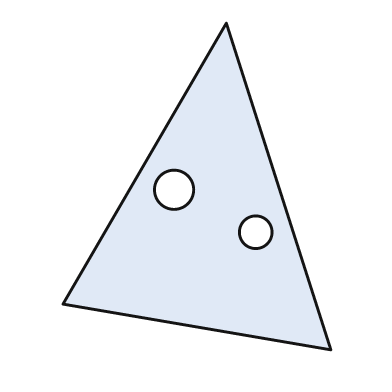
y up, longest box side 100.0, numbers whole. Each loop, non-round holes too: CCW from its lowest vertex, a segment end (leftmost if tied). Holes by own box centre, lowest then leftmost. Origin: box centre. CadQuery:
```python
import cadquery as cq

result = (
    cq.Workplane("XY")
    .moveTo(41.0, -50.0)
    .lineTo(9.0, 50.0)
    .lineTo(-41.0, -36.0)
    .close()
    .moveTo(18.0, -14.0)
    .circle(5.0)
    .moveTo(-7.0, -1.0)
    .circle(6.0)
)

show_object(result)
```